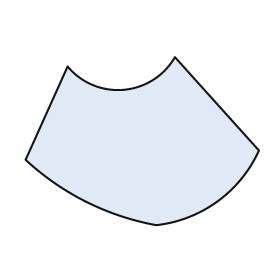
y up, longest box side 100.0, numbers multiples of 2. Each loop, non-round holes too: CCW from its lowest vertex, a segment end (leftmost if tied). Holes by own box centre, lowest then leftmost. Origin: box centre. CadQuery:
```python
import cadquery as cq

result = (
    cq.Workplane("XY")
    .moveTo(6.0, -36.0)
    .threePointArc((32.0, -26.0), (50.0, -4.0))
    .lineTo(14.0, 36.0)
    .threePointArc((-8.0, 22.0), (-32.0, 32.0))
    .lineTo(-50.0, -8.0)
    .threePointArc((-24.0, -26.0), (6.0, -36.0))
    .close()
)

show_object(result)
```